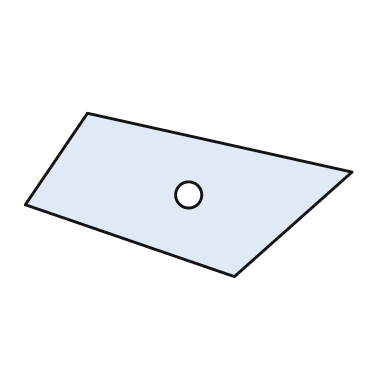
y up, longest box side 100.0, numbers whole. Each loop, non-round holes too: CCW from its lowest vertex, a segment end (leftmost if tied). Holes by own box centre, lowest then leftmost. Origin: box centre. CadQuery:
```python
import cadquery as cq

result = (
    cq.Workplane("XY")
    .moveTo(14.0, -25.0)
    .lineTo(50.0, 7.0)
    .lineTo(-31.0, 25.0)
    .lineTo(-50.0, -3.0)
    .close()
    .moveTo(0.0, 0.0)
    .circle(4.0)
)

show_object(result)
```